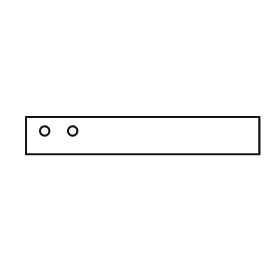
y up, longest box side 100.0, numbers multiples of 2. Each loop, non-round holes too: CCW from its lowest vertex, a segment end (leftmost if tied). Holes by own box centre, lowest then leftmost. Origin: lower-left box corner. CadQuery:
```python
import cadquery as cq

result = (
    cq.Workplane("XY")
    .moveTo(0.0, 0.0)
    .lineTo(100.0, 0.0)
    .lineTo(100.0, 16.0)
    .lineTo(0.0, 16.0)
    .close()
    .moveTo(8.0, 10.0)
    .circle(2.0)
    .moveTo(20.0, 10.0)
    .circle(2.0)
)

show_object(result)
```